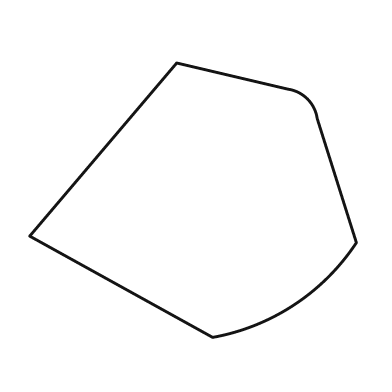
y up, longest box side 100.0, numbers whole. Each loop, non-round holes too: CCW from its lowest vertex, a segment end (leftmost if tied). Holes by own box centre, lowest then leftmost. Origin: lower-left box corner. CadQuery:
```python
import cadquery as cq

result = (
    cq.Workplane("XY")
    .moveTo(56.0, 0.0)
    .threePointArc((81.0, 10.0), (100.0, 29.0))
    .lineTo(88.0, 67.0)
    .threePointArc((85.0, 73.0), (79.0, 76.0))
    .lineTo(45.0, 84.0)
    .lineTo(0.0, 31.0)
    .close()
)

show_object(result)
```